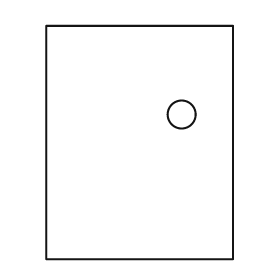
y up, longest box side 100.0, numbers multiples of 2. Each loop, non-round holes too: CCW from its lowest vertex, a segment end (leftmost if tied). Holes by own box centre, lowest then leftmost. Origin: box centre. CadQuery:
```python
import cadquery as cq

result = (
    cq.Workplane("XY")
    .moveTo(-40.0, -50.0)
    .lineTo(40.0, -50.0)
    .lineTo(40.0, 50.0)
    .lineTo(-40.0, 50.0)
    .close()
    .moveTo(18.0, 12.0)
    .circle(6.0)
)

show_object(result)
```